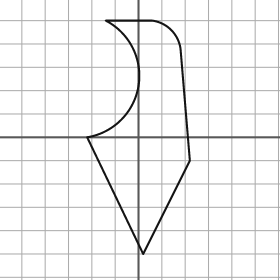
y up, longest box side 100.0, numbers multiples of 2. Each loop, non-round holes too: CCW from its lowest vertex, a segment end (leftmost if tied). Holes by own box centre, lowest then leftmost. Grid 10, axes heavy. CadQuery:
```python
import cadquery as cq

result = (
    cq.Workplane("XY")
    .moveTo(2.0, -50.0)
    .lineTo(22.0, -10.0)
    .lineTo(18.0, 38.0)
    .threePointArc((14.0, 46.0), (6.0, 50.0))
    .lineTo(-14.0, 50.0)
    .threePointArc((0.0, 22.0), (-22.0, 0.0))
    .close()
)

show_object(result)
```